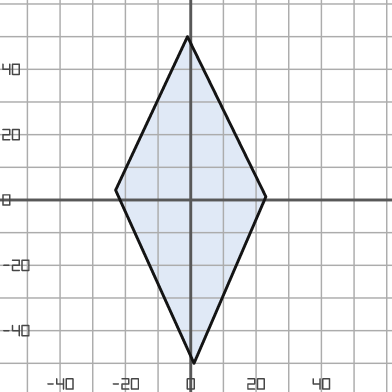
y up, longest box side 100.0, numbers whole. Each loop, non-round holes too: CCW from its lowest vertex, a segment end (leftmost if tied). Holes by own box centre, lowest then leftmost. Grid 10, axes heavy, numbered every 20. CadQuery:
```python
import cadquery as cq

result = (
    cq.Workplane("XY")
    .moveTo(1.0, -50.0)
    .lineTo(23.0, 1.0)
    .lineTo(-1.0, 50.0)
    .lineTo(-23.0, 3.0)
    .close()
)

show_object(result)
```